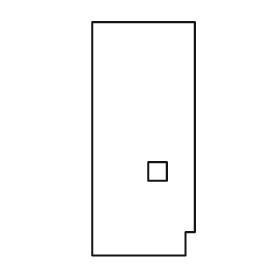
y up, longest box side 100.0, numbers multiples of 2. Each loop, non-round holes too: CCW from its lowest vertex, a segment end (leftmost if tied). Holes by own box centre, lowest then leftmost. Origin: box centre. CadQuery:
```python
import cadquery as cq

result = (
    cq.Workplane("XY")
    .moveTo(-22.0, -50.0)
    .lineTo(18.0, -50.0)
    .lineTo(18.0, -40.0)
    .lineTo(22.0, -40.0)
    .lineTo(22.0, 50.0)
    .lineTo(-22.0, 50.0)
    .close()
    .moveTo(2.0, -18.0)
    .lineTo(10.0, -18.0)
    .lineTo(10.0, -10.0)
    .lineTo(2.0, -10.0)
    .close()
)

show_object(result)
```